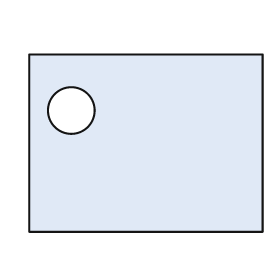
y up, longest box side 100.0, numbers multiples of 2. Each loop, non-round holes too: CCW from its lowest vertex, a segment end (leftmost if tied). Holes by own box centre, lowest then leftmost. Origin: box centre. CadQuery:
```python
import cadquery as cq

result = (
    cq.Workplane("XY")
    .moveTo(-50.0, -38.0)
    .lineTo(50.0, -38.0)
    .lineTo(50.0, 38.0)
    .lineTo(-50.0, 38.0)
    .close()
    .moveTo(-32.0, 14.0)
    .circle(10.0)
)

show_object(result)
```